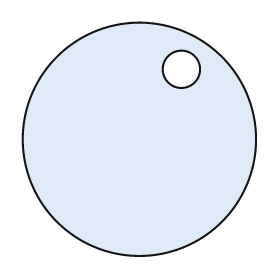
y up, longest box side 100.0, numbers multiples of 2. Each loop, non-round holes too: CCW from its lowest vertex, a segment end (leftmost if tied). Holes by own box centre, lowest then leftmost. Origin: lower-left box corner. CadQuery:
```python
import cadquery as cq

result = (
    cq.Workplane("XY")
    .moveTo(50.0, 50.0)
    .circle(50.0)
    .moveTo(68.0, 80.0)
    .circle(8.0)
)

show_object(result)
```